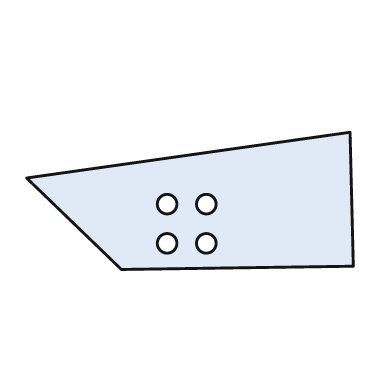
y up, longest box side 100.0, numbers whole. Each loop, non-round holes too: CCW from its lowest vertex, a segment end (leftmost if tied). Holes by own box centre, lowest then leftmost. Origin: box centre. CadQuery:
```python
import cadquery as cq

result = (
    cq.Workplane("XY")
    .moveTo(-21.0, -21.0)
    .lineTo(50.0, -20.0)
    .lineTo(49.0, 21.0)
    .lineTo(-50.0, 7.0)
    .close()
    .moveTo(-7.0, -13.0)
    .circle(3.0)
    .moveTo(5.0, -13.0)
    .circle(3.0)
    .moveTo(-7.0, -1.0)
    .circle(3.0)
    .moveTo(5.0, -1.0)
    .circle(3.0)
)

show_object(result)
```